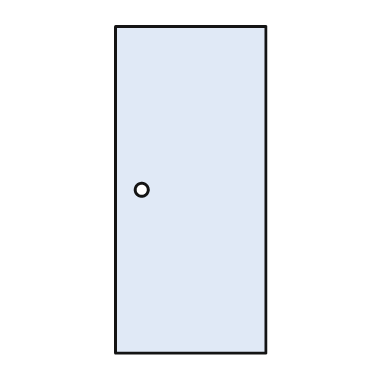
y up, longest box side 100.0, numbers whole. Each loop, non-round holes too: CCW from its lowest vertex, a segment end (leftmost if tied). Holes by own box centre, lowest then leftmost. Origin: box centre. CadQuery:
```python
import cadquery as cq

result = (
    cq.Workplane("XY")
    .moveTo(-23.0, -50.0)
    .lineTo(23.0, -50.0)
    .lineTo(23.0, 50.0)
    .lineTo(-23.0, 50.0)
    .close()
    .moveTo(-15.0, 0.0)
    .circle(2.0)
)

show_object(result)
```